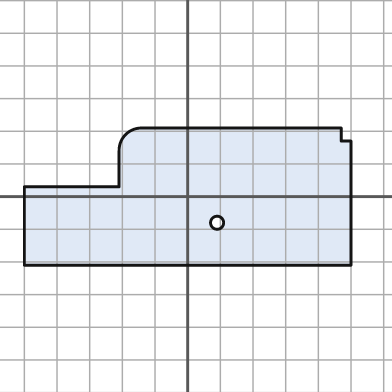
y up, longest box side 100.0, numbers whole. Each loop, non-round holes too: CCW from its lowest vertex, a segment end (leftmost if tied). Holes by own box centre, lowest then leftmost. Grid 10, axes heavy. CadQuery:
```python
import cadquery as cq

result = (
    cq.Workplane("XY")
    .moveTo(-50.0, -21.0)
    .lineTo(50.0, -21.0)
    .lineTo(50.0, 17.0)
    .lineTo(47.0, 17.0)
    .lineTo(47.0, 21.0)
    .lineTo(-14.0, 21.0)
    .threePointArc((-19.0, 19.0), (-21.0, 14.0))
    .lineTo(-21.0, 3.0)
    .lineTo(-50.0, 3.0)
    .close()
    .moveTo(9.0, -8.0)
    .circle(2.0)
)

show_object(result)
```